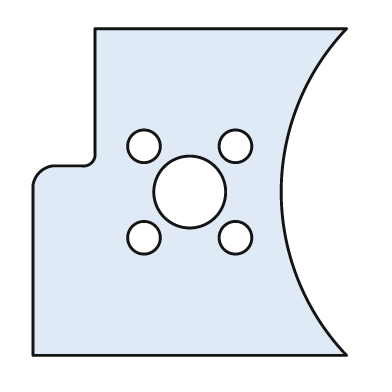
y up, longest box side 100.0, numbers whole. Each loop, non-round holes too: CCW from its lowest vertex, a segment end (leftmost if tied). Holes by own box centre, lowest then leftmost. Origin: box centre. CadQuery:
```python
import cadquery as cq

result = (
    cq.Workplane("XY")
    .moveTo(-48.0, -50.0)
    .lineTo(48.0, -50.0)
    .threePointArc((28.0, 0.0), (48.0, 50.0))
    .lineTo(-29.0, 50.0)
    .lineTo(-29.0, 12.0)
    .threePointArc((-30.0, 9.0), (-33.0, 8.0))
    .lineTo(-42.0, 8.0)
    .threePointArc((-46.0, 6.0), (-48.0, 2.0))
    .close()
    .moveTo(-14.0, -14.0)
    .circle(5.0)
    .moveTo(14.0, -14.0)
    .circle(5.0)
    .moveTo(0.0, 0.0)
    .circle(11.0)
    .moveTo(-14.0, 14.0)
    .circle(5.0)
    .moveTo(14.0, 14.0)
    .circle(5.0)
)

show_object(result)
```